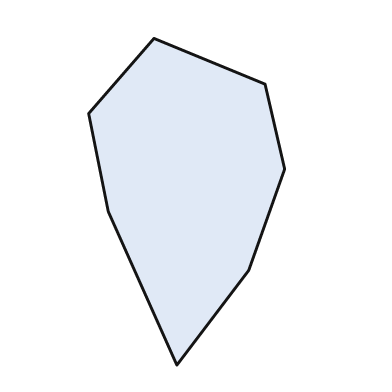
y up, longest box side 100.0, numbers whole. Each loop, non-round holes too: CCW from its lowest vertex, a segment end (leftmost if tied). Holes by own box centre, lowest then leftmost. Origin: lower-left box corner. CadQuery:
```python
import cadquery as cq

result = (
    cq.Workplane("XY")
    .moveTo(27.0, 0.0)
    .lineTo(49.0, 29.0)
    .lineTo(60.0, 60.0)
    .lineTo(54.0, 86.0)
    .lineTo(20.0, 100.0)
    .lineTo(0.0, 77.0)
    .lineTo(6.0, 47.0)
    .close()
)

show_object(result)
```